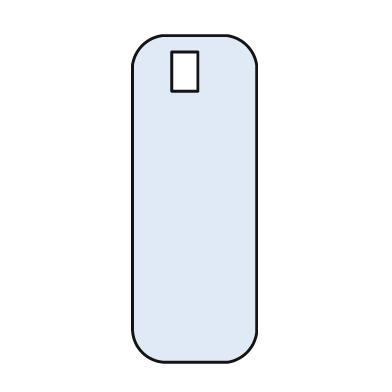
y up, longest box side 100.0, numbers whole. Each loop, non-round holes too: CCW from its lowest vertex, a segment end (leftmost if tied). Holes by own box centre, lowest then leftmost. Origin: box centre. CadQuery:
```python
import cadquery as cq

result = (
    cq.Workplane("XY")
    .moveTo(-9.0, -50.0)
    .lineTo(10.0, -50.0)
    .threePointArc((16.0, -47.0), (19.0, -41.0))
    .lineTo(19.0, 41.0)
    .threePointArc((16.0, 47.0), (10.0, 50.0))
    .lineTo(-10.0, 50.0)
    .threePointArc((-16.0, 47.0), (-19.0, 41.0))
    .lineTo(-19.0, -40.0)
    .threePointArc((-16.0, -47.0), (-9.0, -50.0))
    .close()
    .moveTo(-7.0, 33.0)
    .lineTo(1.0, 33.0)
    .lineTo(1.0, 45.0)
    .lineTo(-7.0, 45.0)
    .close()
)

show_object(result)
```